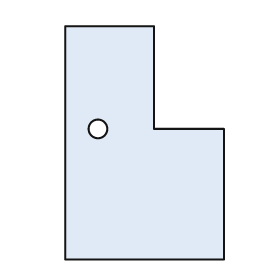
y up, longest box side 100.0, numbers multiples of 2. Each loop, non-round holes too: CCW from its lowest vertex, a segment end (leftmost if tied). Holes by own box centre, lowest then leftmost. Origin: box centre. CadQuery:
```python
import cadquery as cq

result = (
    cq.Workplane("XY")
    .moveTo(-34.0, -50.0)
    .lineTo(34.0, -50.0)
    .lineTo(34.0, 6.0)
    .lineTo(4.0, 6.0)
    .lineTo(4.0, 50.0)
    .lineTo(-34.0, 50.0)
    .close()
    .moveTo(-20.0, 6.0)
    .circle(4.0)
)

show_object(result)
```